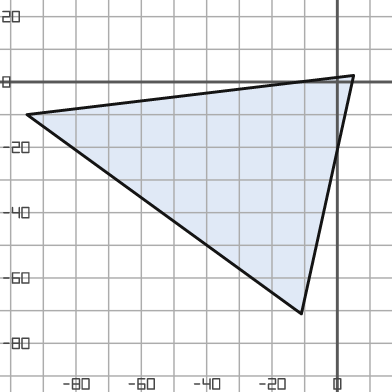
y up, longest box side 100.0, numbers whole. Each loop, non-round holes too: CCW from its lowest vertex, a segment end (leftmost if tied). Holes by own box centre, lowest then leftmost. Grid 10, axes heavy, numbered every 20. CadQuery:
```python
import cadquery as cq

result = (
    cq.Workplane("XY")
    .moveTo(-11.0, -71.0)
    .lineTo(5.0, 2.0)
    .lineTo(-95.0, -10.0)
    .close()
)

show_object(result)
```